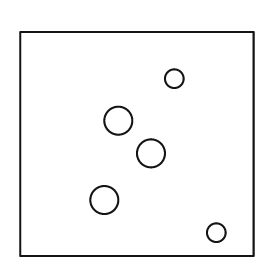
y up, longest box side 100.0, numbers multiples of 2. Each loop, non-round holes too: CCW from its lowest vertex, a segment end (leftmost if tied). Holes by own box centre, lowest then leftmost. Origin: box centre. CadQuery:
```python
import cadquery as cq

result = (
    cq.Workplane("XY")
    .moveTo(-50.0, -48.0)
    .lineTo(50.0, -48.0)
    .lineTo(50.0, 48.0)
    .lineTo(-50.0, 48.0)
    .close()
    .moveTo(34.0, -38.0)
    .circle(4.0)
    .moveTo(-14.0, -24.0)
    .circle(6.0)
    .moveTo(6.0, -4.0)
    .circle(6.0)
    .moveTo(-8.0, 10.0)
    .circle(6.0)
    .moveTo(16.0, 28.0)
    .circle(4.0)
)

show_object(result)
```